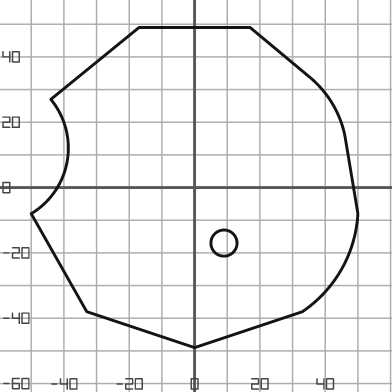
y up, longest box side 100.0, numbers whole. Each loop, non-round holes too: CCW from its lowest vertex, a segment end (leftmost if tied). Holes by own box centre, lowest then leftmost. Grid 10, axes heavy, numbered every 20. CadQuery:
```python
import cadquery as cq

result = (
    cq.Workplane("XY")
    .moveTo(0.0, -49.0)
    .lineTo(33.0, -38.0)
    .threePointArc((45.0, -25.0), (50.0, -8.0))
    .lineTo(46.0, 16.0)
    .threePointArc((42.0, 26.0), (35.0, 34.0))
    .lineTo(17.0, 49.0)
    .lineTo(-17.0, 49.0)
    .lineTo(-44.0, 27.0)
    .threePointArc((-39.0, 8.0), (-50.0, -8.0))
    .lineTo(-33.0, -38.0)
    .close()
    .moveTo(9.0, -17.0)
    .circle(4.0)
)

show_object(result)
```